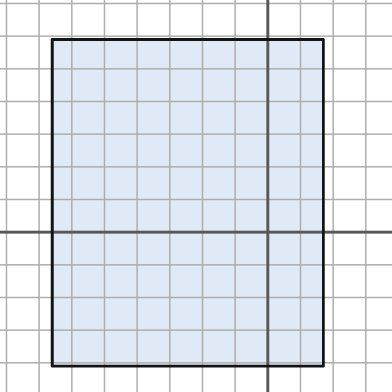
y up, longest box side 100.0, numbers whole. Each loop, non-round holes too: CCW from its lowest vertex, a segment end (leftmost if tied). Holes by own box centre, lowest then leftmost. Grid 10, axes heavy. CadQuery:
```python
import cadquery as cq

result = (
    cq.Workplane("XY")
    .moveTo(-66.0, -41.0)
    .lineTo(17.0, -41.0)
    .lineTo(17.0, 59.0)
    .lineTo(-66.0, 59.0)
    .close()
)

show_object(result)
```